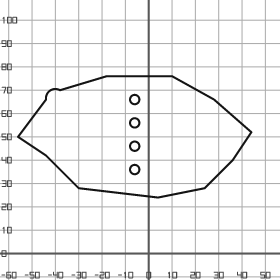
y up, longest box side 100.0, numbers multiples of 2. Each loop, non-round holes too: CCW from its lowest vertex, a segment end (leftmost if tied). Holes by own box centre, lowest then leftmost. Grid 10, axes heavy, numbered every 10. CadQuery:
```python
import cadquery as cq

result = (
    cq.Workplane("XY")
    .moveTo(4.0, 24.0)
    .lineTo(24.0, 28.0)
    .lineTo(36.0, 40.0)
    .lineTo(44.0, 52.0)
    .lineTo(28.0, 66.0)
    .lineTo(10.0, 76.0)
    .lineTo(-18.0, 76.0)
    .lineTo(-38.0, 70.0)
    .threePointArc((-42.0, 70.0), (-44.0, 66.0))
    .lineTo(-56.0, 50.0)
    .lineTo(-44.0, 42.0)
    .lineTo(-30.0, 28.0)
    .close()
    .moveTo(-6.0, 36.0)
    .circle(2.0)
    .moveTo(-6.0, 46.0)
    .circle(2.0)
    .moveTo(-6.0, 56.0)
    .circle(2.0)
    .moveTo(-6.0, 66.0)
    .circle(2.0)
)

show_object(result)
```